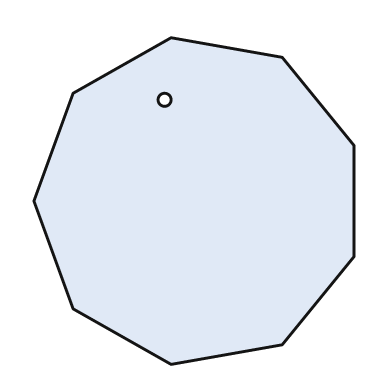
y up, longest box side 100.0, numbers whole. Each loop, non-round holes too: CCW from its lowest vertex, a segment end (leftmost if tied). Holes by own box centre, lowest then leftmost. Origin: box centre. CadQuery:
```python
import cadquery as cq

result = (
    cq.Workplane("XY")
    .moveTo(-7.0, -50.0)
    .lineTo(27.0, -44.0)
    .lineTo(49.0, -17.0)
    .lineTo(49.0, 17.0)
    .lineTo(27.0, 44.0)
    .lineTo(-7.0, 50.0)
    .lineTo(-37.0, 33.0)
    .lineTo(-49.0, 0.0)
    .lineTo(-37.0, -33.0)
    .close()
    .moveTo(-9.0, 31.0)
    .circle(2.0)
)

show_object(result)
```